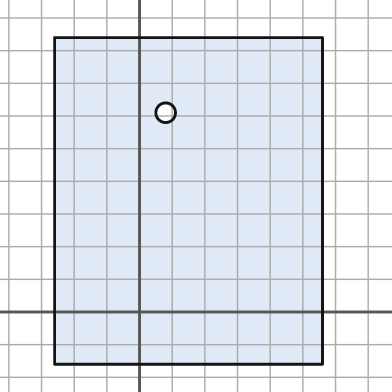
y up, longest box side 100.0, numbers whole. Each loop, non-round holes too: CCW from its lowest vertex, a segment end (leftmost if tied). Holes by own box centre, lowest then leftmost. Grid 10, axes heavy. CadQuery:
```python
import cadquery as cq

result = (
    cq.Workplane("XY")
    .moveTo(-26.0, -16.0)
    .lineTo(56.0, -16.0)
    .lineTo(56.0, 84.0)
    .lineTo(-26.0, 84.0)
    .close()
    .moveTo(8.0, 61.0)
    .circle(3.0)
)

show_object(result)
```